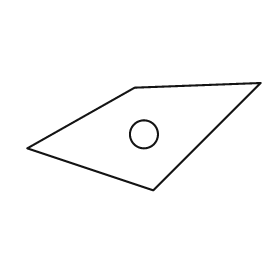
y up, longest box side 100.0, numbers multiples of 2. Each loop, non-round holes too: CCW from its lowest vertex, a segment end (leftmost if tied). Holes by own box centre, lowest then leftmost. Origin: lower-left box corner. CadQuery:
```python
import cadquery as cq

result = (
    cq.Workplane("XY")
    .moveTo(54.0, 0.0)
    .lineTo(100.0, 46.0)
    .lineTo(46.0, 44.0)
    .lineTo(0.0, 18.0)
    .close()
    .moveTo(50.0, 24.0)
    .circle(6.0)
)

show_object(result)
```